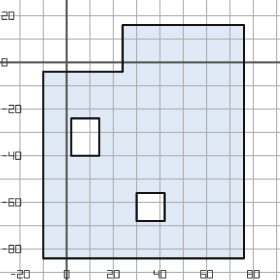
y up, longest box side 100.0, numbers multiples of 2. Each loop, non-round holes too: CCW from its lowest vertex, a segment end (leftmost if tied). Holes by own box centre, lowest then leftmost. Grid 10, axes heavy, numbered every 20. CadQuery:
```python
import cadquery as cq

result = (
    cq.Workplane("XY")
    .moveTo(-10.0, -84.0)
    .lineTo(76.0, -84.0)
    .lineTo(76.0, 16.0)
    .lineTo(24.0, 16.0)
    .lineTo(24.0, -4.0)
    .lineTo(-10.0, -4.0)
    .close()
    .moveTo(30.0, -68.0)
    .lineTo(42.0, -68.0)
    .lineTo(42.0, -56.0)
    .lineTo(30.0, -56.0)
    .close()
    .moveTo(2.0, -40.0)
    .lineTo(14.0, -40.0)
    .lineTo(14.0, -24.0)
    .lineTo(2.0, -24.0)
    .close()
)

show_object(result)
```